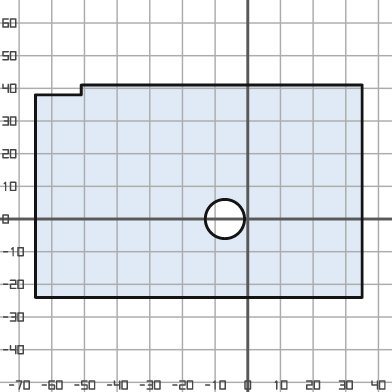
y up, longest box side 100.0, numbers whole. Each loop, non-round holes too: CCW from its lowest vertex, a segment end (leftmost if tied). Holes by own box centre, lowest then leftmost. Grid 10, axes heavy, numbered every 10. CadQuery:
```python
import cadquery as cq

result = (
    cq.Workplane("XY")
    .moveTo(-65.0, -24.0)
    .lineTo(35.0, -24.0)
    .lineTo(35.0, 41.0)
    .lineTo(-51.0, 41.0)
    .lineTo(-51.0, 38.0)
    .lineTo(-65.0, 38.0)
    .close()
    .moveTo(-7.0, 0.0)
    .circle(6.0)
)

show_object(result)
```